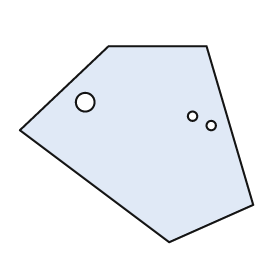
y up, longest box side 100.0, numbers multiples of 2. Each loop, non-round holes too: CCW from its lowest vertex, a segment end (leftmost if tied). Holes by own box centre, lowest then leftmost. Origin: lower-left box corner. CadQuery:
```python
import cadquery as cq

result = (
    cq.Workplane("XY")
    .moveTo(64.0, 0.0)
    .lineTo(100.0, 16.0)
    .lineTo(80.0, 84.0)
    .lineTo(38.0, 84.0)
    .lineTo(0.0, 48.0)
    .close()
    .moveTo(82.0, 50.0)
    .circle(2.0)
    .moveTo(74.0, 54.0)
    .circle(2.0)
    .moveTo(28.0, 60.0)
    .circle(4.0)
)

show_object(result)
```